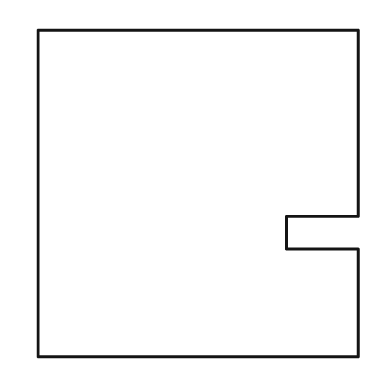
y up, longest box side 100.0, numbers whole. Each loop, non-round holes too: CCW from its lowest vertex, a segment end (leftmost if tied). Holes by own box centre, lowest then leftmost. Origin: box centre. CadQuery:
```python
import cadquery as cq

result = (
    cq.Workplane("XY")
    .moveTo(-49.0, -50.0)
    .lineTo(49.0, -50.0)
    .lineTo(49.0, -17.0)
    .lineTo(27.0, -17.0)
    .lineTo(27.0, -7.0)
    .lineTo(49.0, -7.0)
    .lineTo(49.0, 50.0)
    .lineTo(-49.0, 50.0)
    .close()
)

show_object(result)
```